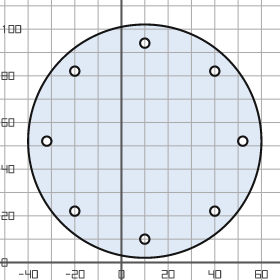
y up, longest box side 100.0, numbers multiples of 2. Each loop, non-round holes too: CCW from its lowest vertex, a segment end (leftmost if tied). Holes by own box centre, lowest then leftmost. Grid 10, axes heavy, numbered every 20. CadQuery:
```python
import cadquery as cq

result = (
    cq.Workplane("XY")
    .moveTo(10.0, 52.0)
    .circle(50.0)
    .moveTo(10.0, 10.0)
    .circle(2.0)
    .moveTo(-20.0, 22.0)
    .circle(2.0)
    .moveTo(40.0, 22.0)
    .circle(2.0)
    .moveTo(-32.0, 52.0)
    .circle(2.0)
    .moveTo(52.0, 52.0)
    .circle(2.0)
    .moveTo(-20.0, 82.0)
    .circle(2.0)
    .moveTo(40.0, 82.0)
    .circle(2.0)
    .moveTo(10.0, 94.0)
    .circle(2.0)
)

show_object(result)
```